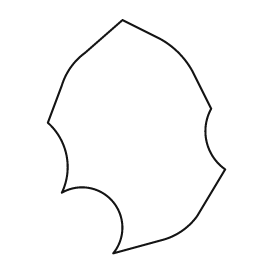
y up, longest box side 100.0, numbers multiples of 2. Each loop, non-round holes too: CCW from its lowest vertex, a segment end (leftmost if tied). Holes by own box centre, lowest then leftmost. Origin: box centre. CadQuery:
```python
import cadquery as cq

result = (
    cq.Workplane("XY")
    .moveTo(-10.0, -50.0)
    .lineTo(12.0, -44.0)
    .threePointArc((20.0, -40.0), (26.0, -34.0))
    .lineTo(38.0, -14.0)
    .threePointArc((30.0, -2.0), (32.0, 12.0))
    .lineTo(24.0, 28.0)
    .threePointArc((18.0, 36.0), (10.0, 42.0))
    .lineTo(-6.0, 50.0)
    .lineTo(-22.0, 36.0)
    .threePointArc((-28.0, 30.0), (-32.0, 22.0))
    .lineTo(-38.0, 6.0)
    .threePointArc((-30.0, -8.0), (-32.0, -24.0))
    .threePointArc((-10.0, -28.0), (-10.0, -50.0))
    .close()
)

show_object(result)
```